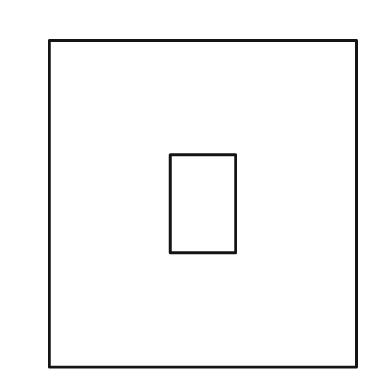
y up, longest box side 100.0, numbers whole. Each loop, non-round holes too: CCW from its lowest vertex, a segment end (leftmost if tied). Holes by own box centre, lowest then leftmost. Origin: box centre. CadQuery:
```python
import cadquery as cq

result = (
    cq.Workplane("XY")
    .moveTo(-47.0, -50.0)
    .lineTo(47.0, -50.0)
    .lineTo(47.0, 50.0)
    .lineTo(-47.0, 50.0)
    .close()
    .moveTo(-10.0, -15.0)
    .lineTo(10.0, -15.0)
    .lineTo(10.0, 15.0)
    .lineTo(-10.0, 15.0)
    .close()
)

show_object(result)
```